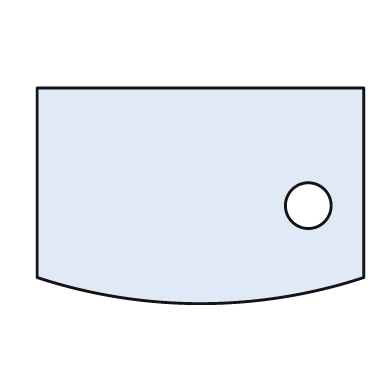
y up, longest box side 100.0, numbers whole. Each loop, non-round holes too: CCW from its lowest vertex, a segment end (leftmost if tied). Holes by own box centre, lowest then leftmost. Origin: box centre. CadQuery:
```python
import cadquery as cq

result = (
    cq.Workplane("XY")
    .moveTo(-50.0, -25.0)
    .threePointArc((0.0, -33.0), (50.0, -25.0))
    .lineTo(50.0, 33.0)
    .lineTo(-50.0, 33.0)
    .close()
    .moveTo(33.0, -3.0)
    .circle(7.0)
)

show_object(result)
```